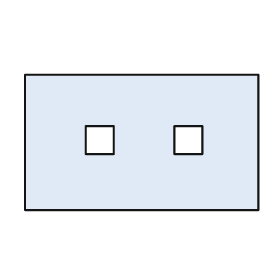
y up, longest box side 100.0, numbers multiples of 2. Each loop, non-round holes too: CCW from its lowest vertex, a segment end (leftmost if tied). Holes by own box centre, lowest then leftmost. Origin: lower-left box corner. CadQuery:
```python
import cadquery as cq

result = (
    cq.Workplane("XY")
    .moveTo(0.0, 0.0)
    .lineTo(100.0, 0.0)
    .lineTo(100.0, 58.0)
    .lineTo(0.0, 58.0)
    .close()
    .moveTo(26.0, 24.0)
    .lineTo(38.0, 24.0)
    .lineTo(38.0, 36.0)
    .lineTo(26.0, 36.0)
    .close()
    .moveTo(64.0, 24.0)
    .lineTo(76.0, 24.0)
    .lineTo(76.0, 36.0)
    .lineTo(64.0, 36.0)
    .close()
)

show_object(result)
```